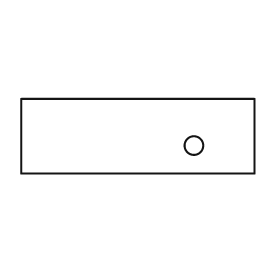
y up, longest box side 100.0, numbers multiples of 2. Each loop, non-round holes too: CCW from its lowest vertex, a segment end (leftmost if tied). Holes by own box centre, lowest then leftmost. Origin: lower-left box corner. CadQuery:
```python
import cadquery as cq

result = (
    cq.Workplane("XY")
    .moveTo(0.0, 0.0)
    .lineTo(100.0, 0.0)
    .lineTo(100.0, 32.0)
    .lineTo(0.0, 32.0)
    .close()
    .moveTo(74.0, 12.0)
    .circle(4.0)
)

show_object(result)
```